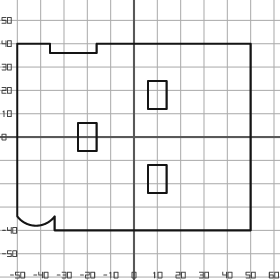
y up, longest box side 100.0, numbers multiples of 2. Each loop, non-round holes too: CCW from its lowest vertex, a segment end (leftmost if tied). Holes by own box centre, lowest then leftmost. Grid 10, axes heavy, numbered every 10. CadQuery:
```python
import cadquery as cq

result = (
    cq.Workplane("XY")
    .moveTo(-34.0, -40.0)
    .lineTo(50.0, -40.0)
    .lineTo(50.0, 40.0)
    .lineTo(-16.0, 40.0)
    .lineTo(-16.0, 36.0)
    .lineTo(-36.0, 36.0)
    .lineTo(-36.0, 40.0)
    .lineTo(-50.0, 40.0)
    .lineTo(-50.0, -34.0)
    .threePointArc((-42.0, -38.0), (-34.0, -34.0))
    .close()
    .moveTo(6.0, -24.0)
    .lineTo(14.0, -24.0)
    .lineTo(14.0, -12.0)
    .lineTo(6.0, -12.0)
    .close()
    .moveTo(-24.0, -6.0)
    .lineTo(-16.0, -6.0)
    .lineTo(-16.0, 6.0)
    .lineTo(-24.0, 6.0)
    .close()
    .moveTo(6.0, 12.0)
    .lineTo(14.0, 12.0)
    .lineTo(14.0, 24.0)
    .lineTo(6.0, 24.0)
    .close()
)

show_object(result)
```